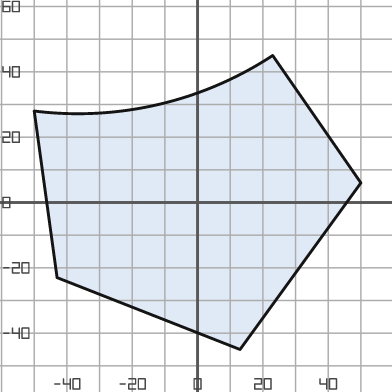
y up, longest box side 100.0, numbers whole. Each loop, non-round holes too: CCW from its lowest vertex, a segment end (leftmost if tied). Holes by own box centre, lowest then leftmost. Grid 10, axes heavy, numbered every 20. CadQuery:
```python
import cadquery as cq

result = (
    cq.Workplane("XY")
    .moveTo(13.0, -45.0)
    .lineTo(50.0, 6.0)
    .lineTo(23.0, 45.0)
    .threePointArc((-12.0, 30.0), (-50.0, 28.0))
    .lineTo(-43.0, -23.0)
    .close()
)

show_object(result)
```